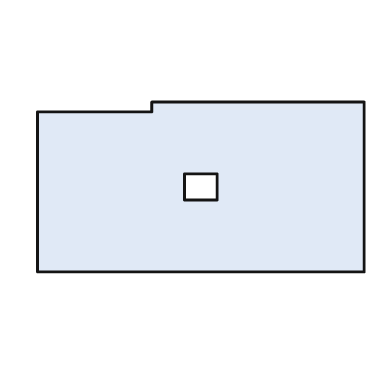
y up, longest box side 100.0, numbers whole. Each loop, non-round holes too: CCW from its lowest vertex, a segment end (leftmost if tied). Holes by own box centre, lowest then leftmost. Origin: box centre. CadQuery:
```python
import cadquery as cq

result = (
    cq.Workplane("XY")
    .moveTo(-50.0, -26.0)
    .lineTo(50.0, -26.0)
    .lineTo(50.0, 26.0)
    .lineTo(-15.0, 26.0)
    .lineTo(-15.0, 23.0)
    .lineTo(-50.0, 23.0)
    .close()
    .moveTo(-5.0, -4.0)
    .lineTo(5.0, -4.0)
    .lineTo(5.0, 4.0)
    .lineTo(-5.0, 4.0)
    .close()
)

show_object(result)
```